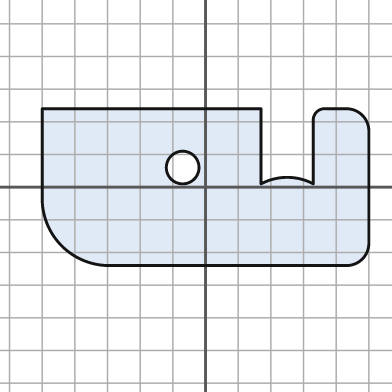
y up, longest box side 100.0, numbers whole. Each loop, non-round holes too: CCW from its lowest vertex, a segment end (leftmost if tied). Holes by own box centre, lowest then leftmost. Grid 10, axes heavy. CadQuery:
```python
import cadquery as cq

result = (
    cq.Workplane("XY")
    .moveTo(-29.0, -24.0)
    .lineTo(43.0, -24.0)
    .threePointArc((48.0, -22.0), (50.0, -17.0))
    .lineTo(50.0, 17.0)
    .threePointArc((48.0, 22.0), (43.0, 24.0))
    .lineTo(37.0, 24.0)
    .threePointArc((34.0, 23.0), (33.0, 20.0))
    .lineTo(33.0, 1.0)
    .threePointArc((25.0, 3.0), (17.0, 1.0))
    .lineTo(17.0, 24.0)
    .lineTo(-50.0, 24.0)
    .lineTo(-50.0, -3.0)
    .threePointArc((-44.0, -18.0), (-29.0, -24.0))
    .close()
    .moveTo(-7.0, 6.0)
    .circle(5.0)
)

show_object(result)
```